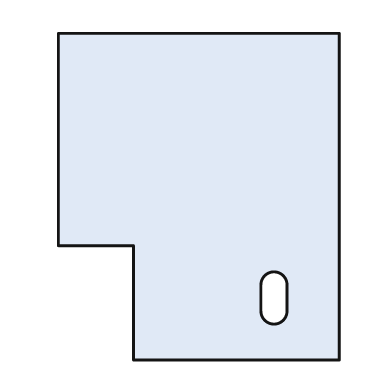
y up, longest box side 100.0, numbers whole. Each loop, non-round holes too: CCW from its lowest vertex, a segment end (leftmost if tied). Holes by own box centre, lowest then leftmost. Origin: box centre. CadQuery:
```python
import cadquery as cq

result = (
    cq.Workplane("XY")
    .moveTo(-20.0, -50.0)
    .lineTo(43.0, -50.0)
    .lineTo(43.0, 50.0)
    .lineTo(-43.0, 50.0)
    .lineTo(-43.0, -15.0)
    .lineTo(-20.0, -15.0)
    .close()
    .moveTo(19.0, -35.0)
    .threePointArc((23.0, -39.0), (27.0, -35.0))
    .lineTo(27.0, -27.0)
    .threePointArc((23.0, -23.0), (19.0, -27.0))
    .close()
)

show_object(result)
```